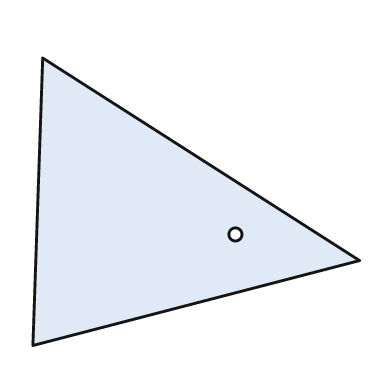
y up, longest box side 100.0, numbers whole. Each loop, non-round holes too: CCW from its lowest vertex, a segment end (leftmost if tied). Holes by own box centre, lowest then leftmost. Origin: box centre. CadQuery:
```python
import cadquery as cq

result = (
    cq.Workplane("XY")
    .moveTo(-50.0, -44.0)
    .lineTo(50.0, -18.0)
    .lineTo(-47.0, 44.0)
    .close()
    .moveTo(12.0, -10.0)
    .circle(2.0)
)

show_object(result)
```